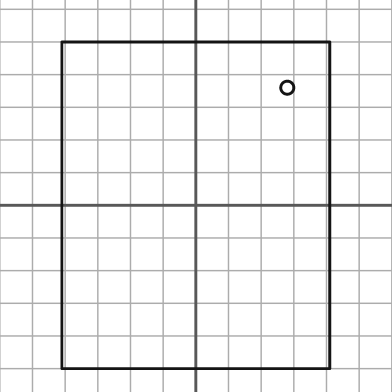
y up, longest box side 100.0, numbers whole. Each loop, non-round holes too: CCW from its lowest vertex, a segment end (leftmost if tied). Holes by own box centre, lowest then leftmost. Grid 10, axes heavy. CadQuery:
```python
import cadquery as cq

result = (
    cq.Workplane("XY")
    .moveTo(-41.0, -50.0)
    .lineTo(41.0, -50.0)
    .lineTo(41.0, 50.0)
    .lineTo(-41.0, 50.0)
    .close()
    .moveTo(28.0, 36.0)
    .circle(2.0)
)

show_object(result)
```